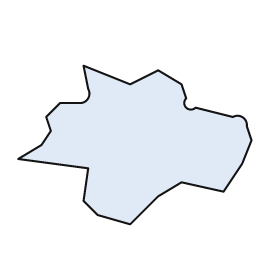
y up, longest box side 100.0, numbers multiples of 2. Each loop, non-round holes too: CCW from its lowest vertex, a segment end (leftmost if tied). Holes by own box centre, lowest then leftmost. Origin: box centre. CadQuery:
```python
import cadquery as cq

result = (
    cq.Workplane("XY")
    .moveTo(-2.0, -34.0)
    .lineTo(10.0, -22.0)
    .lineTo(20.0, -16.0)
    .lineTo(38.0, -20.0)
    .lineTo(46.0, -8.0)
    .lineTo(50.0, 2.0)
    .lineTo(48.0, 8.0)
    .threePointArc((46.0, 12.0), (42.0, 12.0))
    .lineTo(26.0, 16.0)
    .threePointArc((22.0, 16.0), (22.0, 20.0))
    .lineTo(20.0, 26.0)
    .lineTo(10.0, 32.0)
    .lineTo(-2.0, 26.0)
    .lineTo(-22.0, 34.0)
    .lineTo(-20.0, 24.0)
    .threePointArc((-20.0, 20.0), (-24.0, 18.0))
    .lineTo(-32.0, 18.0)
    .lineTo(-38.0, 12.0)
    .lineTo(-36.0, 6.0)
    .lineTo(-40.0, 0.0)
    .lineTo(-50.0, -6.0)
    .lineTo(-20.0, -10.0)
    .lineTo(-22.0, -24.0)
    .lineTo(-16.0, -30.0)
    .close()
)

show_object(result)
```